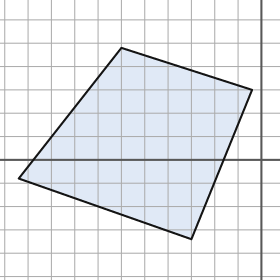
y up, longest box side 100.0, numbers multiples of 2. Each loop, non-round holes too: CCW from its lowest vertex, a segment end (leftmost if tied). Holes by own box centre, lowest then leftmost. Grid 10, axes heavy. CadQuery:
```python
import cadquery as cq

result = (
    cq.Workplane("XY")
    .moveTo(-30.0, -34.0)
    .lineTo(-4.0, 30.0)
    .lineTo(-60.0, 48.0)
    .lineTo(-104.0, -8.0)
    .close()
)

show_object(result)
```